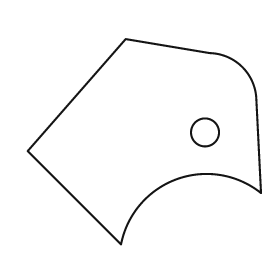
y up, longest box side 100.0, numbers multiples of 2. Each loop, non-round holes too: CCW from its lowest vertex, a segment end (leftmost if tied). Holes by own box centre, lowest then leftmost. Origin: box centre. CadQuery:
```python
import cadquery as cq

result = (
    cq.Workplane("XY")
    .moveTo(-10.0, -44.0)
    .threePointArc((14.0, -16.0), (50.0, -22.0))
    .lineTo(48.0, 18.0)
    .threePointArc((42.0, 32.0), (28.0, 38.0))
    .lineTo(-8.0, 44.0)
    .lineTo(-50.0, -4.0)
    .close()
    .moveTo(26.0, 4.0)
    .circle(6.0)
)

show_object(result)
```